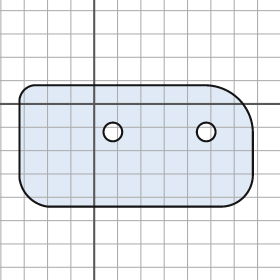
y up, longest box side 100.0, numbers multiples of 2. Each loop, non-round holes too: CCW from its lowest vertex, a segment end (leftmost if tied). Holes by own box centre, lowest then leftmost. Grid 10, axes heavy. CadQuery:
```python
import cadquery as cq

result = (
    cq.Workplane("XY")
    .moveTo(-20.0, -44.0)
    .lineTo(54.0, -44.0)
    .threePointArc((64.0, -40.0), (68.0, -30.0))
    .lineTo(68.0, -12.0)
    .threePointArc((62.0, 2.0), (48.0, 8.0))
    .lineTo(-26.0, 8.0)
    .threePointArc((-30.0, 6.0), (-32.0, 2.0))
    .lineTo(-32.0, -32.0)
    .threePointArc((-28.0, -40.0), (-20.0, -44.0))
    .close()
    .moveTo(8.0, -12.0)
    .circle(4.0)
    .moveTo(48.0, -12.0)
    .circle(4.0)
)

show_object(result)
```